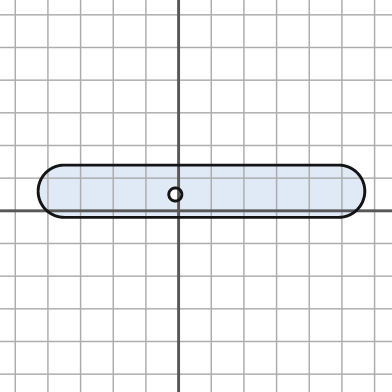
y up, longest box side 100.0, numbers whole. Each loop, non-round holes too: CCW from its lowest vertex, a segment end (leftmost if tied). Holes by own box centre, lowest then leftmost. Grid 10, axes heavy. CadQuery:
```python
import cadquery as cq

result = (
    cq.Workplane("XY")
    .moveTo(-35.0, -2.0)
    .lineTo(49.0, -2.0)
    .threePointArc((57.0, 6.0), (49.0, 14.0))
    .lineTo(-35.0, 14.0)
    .threePointArc((-43.0, 6.0), (-35.0, -2.0))
    .close()
    .moveTo(-1.0, 5.0)
    .circle(2.0)
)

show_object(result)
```